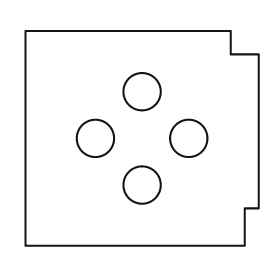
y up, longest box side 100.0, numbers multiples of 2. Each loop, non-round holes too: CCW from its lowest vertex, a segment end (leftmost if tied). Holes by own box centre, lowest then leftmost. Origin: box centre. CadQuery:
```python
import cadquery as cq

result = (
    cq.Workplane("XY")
    .moveTo(-50.0, -46.0)
    .lineTo(44.0, -46.0)
    .lineTo(44.0, -30.0)
    .lineTo(50.0, -30.0)
    .lineTo(50.0, 36.0)
    .lineTo(38.0, 36.0)
    .lineTo(38.0, 46.0)
    .lineTo(-50.0, 46.0)
    .close()
    .moveTo(0.0, -20.0)
    .circle(8.0)
    .moveTo(-20.0, 0.0)
    .circle(8.0)
    .moveTo(20.0, 0.0)
    .circle(8.0)
    .moveTo(0.0, 20.0)
    .circle(8.0)
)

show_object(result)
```